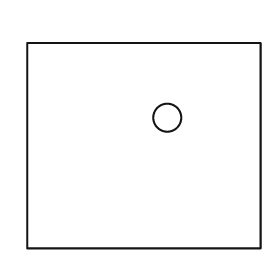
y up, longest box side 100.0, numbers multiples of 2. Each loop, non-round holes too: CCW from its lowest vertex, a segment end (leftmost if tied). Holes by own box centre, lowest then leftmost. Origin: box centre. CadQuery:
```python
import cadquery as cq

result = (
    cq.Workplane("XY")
    .moveTo(-50.0, -44.0)
    .lineTo(50.0, -44.0)
    .lineTo(50.0, 44.0)
    .lineTo(-50.0, 44.0)
    .close()
    .moveTo(10.0, 12.0)
    .circle(6.0)
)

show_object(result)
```